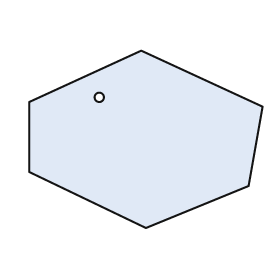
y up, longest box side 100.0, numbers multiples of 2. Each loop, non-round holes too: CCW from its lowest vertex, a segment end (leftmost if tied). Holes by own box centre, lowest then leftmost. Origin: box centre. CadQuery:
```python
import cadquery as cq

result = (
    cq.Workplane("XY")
    .moveTo(0.0, -38.0)
    .lineTo(44.0, -20.0)
    .lineTo(50.0, 14.0)
    .lineTo(-2.0, 38.0)
    .lineTo(-50.0, 16.0)
    .lineTo(-50.0, -14.0)
    .close()
    .moveTo(-20.0, 18.0)
    .circle(2.0)
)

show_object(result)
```